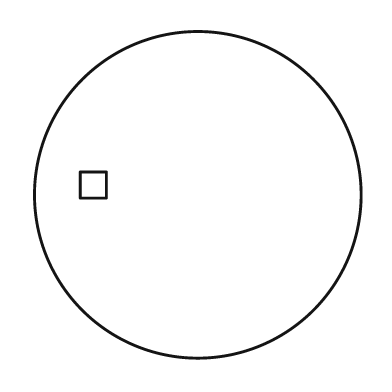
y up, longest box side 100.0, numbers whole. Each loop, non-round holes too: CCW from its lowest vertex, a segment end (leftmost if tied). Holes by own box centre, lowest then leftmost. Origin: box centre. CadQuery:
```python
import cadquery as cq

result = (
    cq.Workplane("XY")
    .moveTo(0.0, 0.0)
    .circle(50.0)
    .moveTo(-36.0, -1.0)
    .lineTo(-28.0, -1.0)
    .lineTo(-28.0, 7.0)
    .lineTo(-36.0, 7.0)
    .close()
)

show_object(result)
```